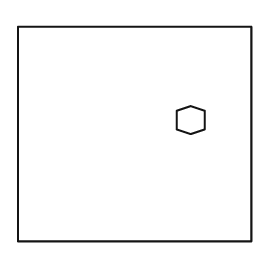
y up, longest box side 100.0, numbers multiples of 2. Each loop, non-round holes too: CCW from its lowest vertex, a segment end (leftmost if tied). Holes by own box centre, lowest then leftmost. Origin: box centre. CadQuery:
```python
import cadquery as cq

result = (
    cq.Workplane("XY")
    .moveTo(-50.0, -46.0)
    .lineTo(50.0, -46.0)
    .lineTo(50.0, 46.0)
    .lineTo(-50.0, 46.0)
    .close()
    .moveTo(24.0, 0.0)
    .lineTo(30.0, 2.0)
    .lineTo(30.0, 10.0)
    .lineTo(24.0, 12.0)
    .lineTo(18.0, 10.0)
    .lineTo(18.0, 2.0)
    .close()
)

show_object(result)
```